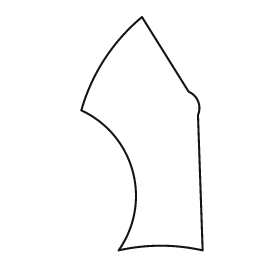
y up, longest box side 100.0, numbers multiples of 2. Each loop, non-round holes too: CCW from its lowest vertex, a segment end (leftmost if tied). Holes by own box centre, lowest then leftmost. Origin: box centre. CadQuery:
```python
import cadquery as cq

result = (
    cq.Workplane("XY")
    .moveTo(-10.0, -50.0)
    .threePointArc((8.0, -48.0), (26.0, -50.0))
    .lineTo(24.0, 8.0)
    .threePointArc((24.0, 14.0), (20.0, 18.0))
    .lineTo(0.0, 50.0)
    .threePointArc((-16.0, 32.0), (-26.0, 10.0))
    .threePointArc((-4.0, -16.0), (-10.0, -50.0))
    .close()
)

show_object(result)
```